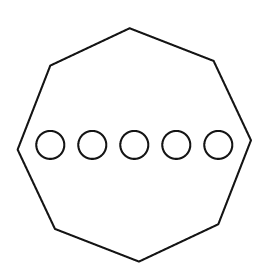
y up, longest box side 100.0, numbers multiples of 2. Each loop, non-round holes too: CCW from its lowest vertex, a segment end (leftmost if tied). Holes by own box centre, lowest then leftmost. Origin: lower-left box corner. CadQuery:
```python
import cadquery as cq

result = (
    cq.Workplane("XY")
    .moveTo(52.0, 0.0)
    .lineTo(86.0, 16.0)
    .lineTo(100.0, 52.0)
    .lineTo(84.0, 86.0)
    .lineTo(48.0, 100.0)
    .lineTo(14.0, 84.0)
    .lineTo(0.0, 48.0)
    .lineTo(16.0, 14.0)
    .close()
    .moveTo(14.0, 50.0)
    .circle(6.0)
    .moveTo(32.0, 50.0)
    .circle(6.0)
    .moveTo(50.0, 50.0)
    .circle(6.0)
    .moveTo(68.0, 50.0)
    .circle(6.0)
    .moveTo(86.0, 50.0)
    .circle(6.0)
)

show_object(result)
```